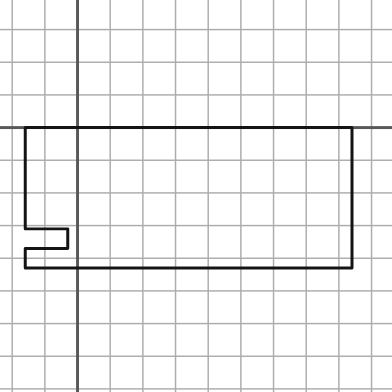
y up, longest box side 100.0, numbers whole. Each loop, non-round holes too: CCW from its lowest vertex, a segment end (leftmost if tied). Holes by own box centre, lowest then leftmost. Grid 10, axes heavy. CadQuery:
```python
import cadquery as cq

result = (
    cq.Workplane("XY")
    .moveTo(-16.0, -43.0)
    .lineTo(84.0, -43.0)
    .lineTo(84.0, 0.0)
    .lineTo(-16.0, 0.0)
    .lineTo(-16.0, -31.0)
    .lineTo(-3.0, -31.0)
    .lineTo(-3.0, -37.0)
    .lineTo(-16.0, -37.0)
    .close()
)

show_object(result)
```